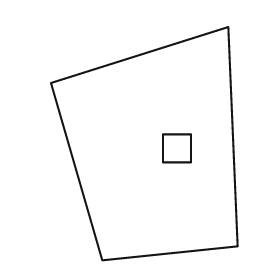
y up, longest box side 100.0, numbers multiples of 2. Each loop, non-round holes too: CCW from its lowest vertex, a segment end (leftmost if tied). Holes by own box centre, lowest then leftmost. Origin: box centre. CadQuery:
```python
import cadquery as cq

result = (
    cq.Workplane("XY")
    .moveTo(-18.0, -50.0)
    .lineTo(40.0, -44.0)
    .lineTo(36.0, 50.0)
    .lineTo(-40.0, 26.0)
    .close()
    .moveTo(8.0, -8.0)
    .lineTo(20.0, -8.0)
    .lineTo(20.0, 4.0)
    .lineTo(8.0, 4.0)
    .close()
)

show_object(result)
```